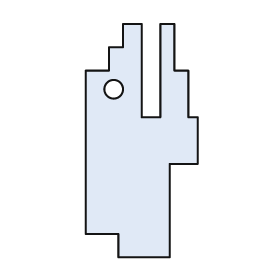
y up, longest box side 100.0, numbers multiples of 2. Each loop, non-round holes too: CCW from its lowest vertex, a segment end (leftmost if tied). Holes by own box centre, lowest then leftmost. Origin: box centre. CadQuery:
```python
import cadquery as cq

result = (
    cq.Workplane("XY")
    .moveTo(-10.0, -50.0)
    .lineTo(12.0, -50.0)
    .lineTo(12.0, -10.0)
    .lineTo(24.0, -10.0)
    .lineTo(24.0, 10.0)
    .lineTo(20.0, 10.0)
    .lineTo(20.0, 30.0)
    .lineTo(14.0, 30.0)
    .lineTo(14.0, 50.0)
    .lineTo(8.0, 50.0)
    .lineTo(8.0, 10.0)
    .lineTo(0.0, 10.0)
    .lineTo(0.0, 50.0)
    .lineTo(-8.0, 50.0)
    .lineTo(-8.0, 40.0)
    .lineTo(-14.0, 40.0)
    .lineTo(-14.0, 30.0)
    .lineTo(-24.0, 30.0)
    .lineTo(-24.0, -40.0)
    .lineTo(-10.0, -40.0)
    .close()
    .moveTo(-12.0, 22.0)
    .circle(4.0)
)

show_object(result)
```